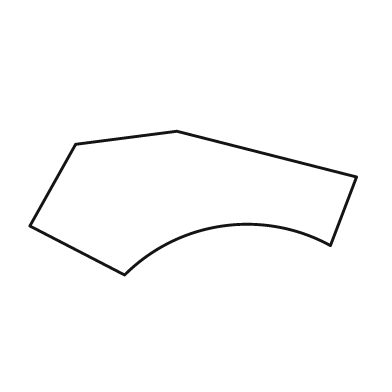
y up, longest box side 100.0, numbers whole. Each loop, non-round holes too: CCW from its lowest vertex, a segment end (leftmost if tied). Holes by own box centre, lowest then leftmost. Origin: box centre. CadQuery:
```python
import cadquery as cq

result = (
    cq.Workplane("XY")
    .moveTo(-21.0, -22.0)
    .threePointArc((9.0, -7.0), (42.0, -13.0))
    .lineTo(50.0, 8.0)
    .lineTo(-5.0, 22.0)
    .lineTo(-36.0, 18.0)
    .lineTo(-50.0, -7.0)
    .close()
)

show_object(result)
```